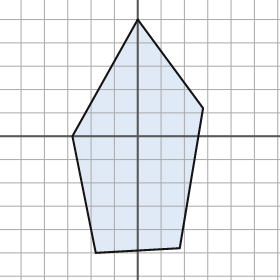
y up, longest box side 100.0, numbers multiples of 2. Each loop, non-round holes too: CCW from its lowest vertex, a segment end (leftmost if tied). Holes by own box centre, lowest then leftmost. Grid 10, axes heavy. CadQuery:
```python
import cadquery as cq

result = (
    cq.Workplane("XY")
    .moveTo(-18.0, -50.0)
    .lineTo(18.0, -48.0)
    .lineTo(28.0, 12.0)
    .lineTo(0.0, 50.0)
    .lineTo(-28.0, 0.0)
    .close()
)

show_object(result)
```